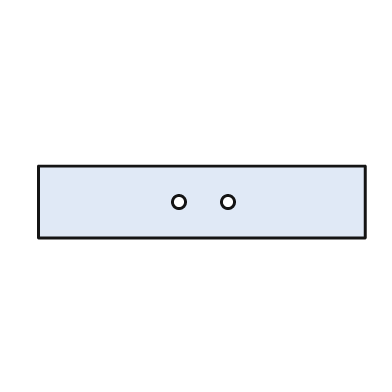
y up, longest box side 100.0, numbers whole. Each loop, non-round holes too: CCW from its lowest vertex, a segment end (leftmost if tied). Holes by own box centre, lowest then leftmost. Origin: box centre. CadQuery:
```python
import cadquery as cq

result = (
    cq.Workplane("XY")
    .moveTo(-50.0, -11.0)
    .lineTo(50.0, -11.0)
    .lineTo(50.0, 11.0)
    .lineTo(-50.0, 11.0)
    .close()
    .moveTo(-7.0, 0.0)
    .circle(2.0)
    .moveTo(8.0, 0.0)
    .circle(2.0)
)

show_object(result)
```